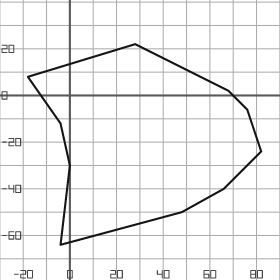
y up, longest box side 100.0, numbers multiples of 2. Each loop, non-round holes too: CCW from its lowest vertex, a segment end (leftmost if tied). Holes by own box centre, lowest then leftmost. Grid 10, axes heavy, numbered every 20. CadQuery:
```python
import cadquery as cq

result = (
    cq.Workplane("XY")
    .moveTo(-4.0, -64.0)
    .lineTo(48.0, -50.0)
    .lineTo(66.0, -40.0)
    .lineTo(82.0, -24.0)
    .lineTo(76.0, -6.0)
    .lineTo(68.0, 2.0)
    .lineTo(28.0, 22.0)
    .lineTo(-18.0, 8.0)
    .lineTo(-4.0, -12.0)
    .lineTo(0.0, -30.0)
    .close()
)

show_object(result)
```